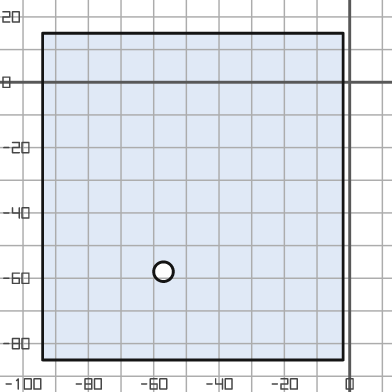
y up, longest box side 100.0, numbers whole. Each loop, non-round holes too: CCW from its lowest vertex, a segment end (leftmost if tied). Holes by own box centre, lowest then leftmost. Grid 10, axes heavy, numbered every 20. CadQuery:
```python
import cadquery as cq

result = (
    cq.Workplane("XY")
    .moveTo(-94.0, -85.0)
    .lineTo(-2.0, -85.0)
    .lineTo(-2.0, 15.0)
    .lineTo(-94.0, 15.0)
    .close()
    .moveTo(-57.0, -58.0)
    .circle(3.0)
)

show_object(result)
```